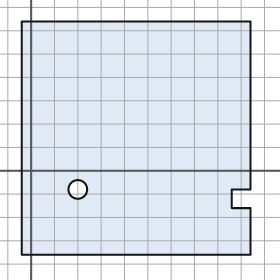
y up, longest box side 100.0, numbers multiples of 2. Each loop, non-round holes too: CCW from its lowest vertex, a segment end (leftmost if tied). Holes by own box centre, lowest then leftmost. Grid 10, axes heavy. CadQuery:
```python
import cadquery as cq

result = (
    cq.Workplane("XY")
    .moveTo(-4.0, -36.0)
    .lineTo(94.0, -36.0)
    .lineTo(94.0, -16.0)
    .lineTo(86.0, -16.0)
    .lineTo(86.0, -8.0)
    .lineTo(94.0, -8.0)
    .lineTo(94.0, 64.0)
    .lineTo(-4.0, 64.0)
    .close()
    .moveTo(20.0, -8.0)
    .circle(4.0)
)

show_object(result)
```